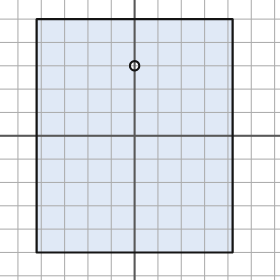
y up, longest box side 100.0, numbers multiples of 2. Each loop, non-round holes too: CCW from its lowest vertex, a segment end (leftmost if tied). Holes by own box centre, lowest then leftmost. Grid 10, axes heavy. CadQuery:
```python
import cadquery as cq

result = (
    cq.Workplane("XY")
    .moveTo(-42.0, -50.0)
    .lineTo(42.0, -50.0)
    .lineTo(42.0, 50.0)
    .lineTo(-42.0, 50.0)
    .close()
    .moveTo(0.0, 30.0)
    .circle(2.0)
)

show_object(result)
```